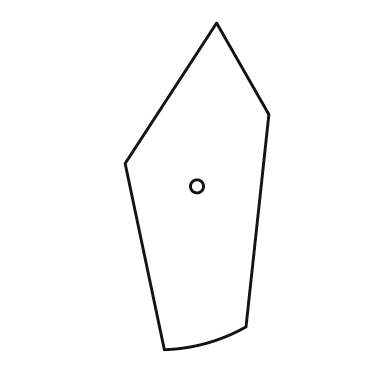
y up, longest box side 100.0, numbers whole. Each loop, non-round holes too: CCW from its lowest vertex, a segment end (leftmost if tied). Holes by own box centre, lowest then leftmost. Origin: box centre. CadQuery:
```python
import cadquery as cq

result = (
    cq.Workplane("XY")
    .moveTo(-10.0, -50.0)
    .threePointArc((3.0, -48.0), (15.0, -43.0))
    .lineTo(22.0, 22.0)
    .lineTo(6.0, 50.0)
    .lineTo(-22.0, 7.0)
    .close()
    .moveTo(0.0, 0.0)
    .circle(2.0)
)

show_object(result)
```